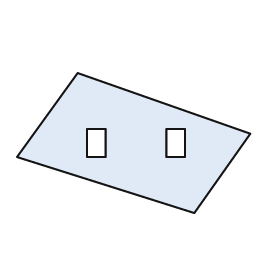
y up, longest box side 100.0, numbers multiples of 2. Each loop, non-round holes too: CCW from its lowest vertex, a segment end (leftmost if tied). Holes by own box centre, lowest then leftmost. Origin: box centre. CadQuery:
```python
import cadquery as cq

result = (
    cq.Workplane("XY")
    .moveTo(26.0, -30.0)
    .lineTo(50.0, 4.0)
    .lineTo(-24.0, 30.0)
    .lineTo(-50.0, -6.0)
    .close()
    .moveTo(-20.0, -6.0)
    .lineTo(-12.0, -6.0)
    .lineTo(-12.0, 6.0)
    .lineTo(-20.0, 6.0)
    .close()
    .moveTo(14.0, -6.0)
    .lineTo(22.0, -6.0)
    .lineTo(22.0, 6.0)
    .lineTo(14.0, 6.0)
    .close()
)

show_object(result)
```